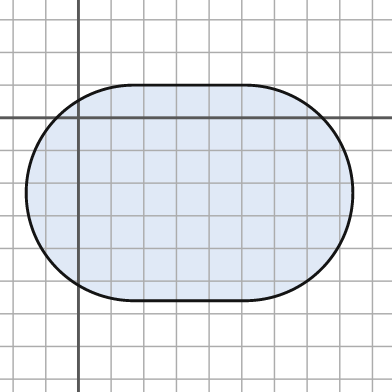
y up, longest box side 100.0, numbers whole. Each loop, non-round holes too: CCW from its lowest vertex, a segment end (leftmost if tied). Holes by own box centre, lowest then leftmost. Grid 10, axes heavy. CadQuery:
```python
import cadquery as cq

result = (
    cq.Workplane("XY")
    .moveTo(17.0, -56.0)
    .lineTo(51.0, -56.0)
    .threePointArc((84.0, -23.0), (51.0, 10.0))
    .lineTo(17.0, 10.0)
    .threePointArc((-16.0, -23.0), (17.0, -56.0))
    .close()
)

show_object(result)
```